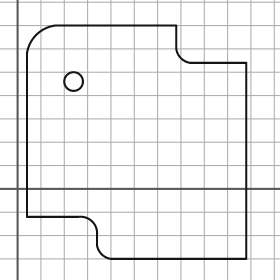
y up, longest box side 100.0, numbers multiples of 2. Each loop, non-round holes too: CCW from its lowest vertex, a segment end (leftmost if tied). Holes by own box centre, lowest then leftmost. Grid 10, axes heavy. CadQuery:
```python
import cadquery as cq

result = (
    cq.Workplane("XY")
    .moveTo(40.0, -30.0)
    .lineTo(98.0, -30.0)
    .lineTo(98.0, 54.0)
    .lineTo(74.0, 54.0)
    .threePointArc((70.0, 56.0), (68.0, 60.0))
    .lineTo(68.0, 70.0)
    .lineTo(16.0, 70.0)
    .threePointArc((8.0, 66.0), (4.0, 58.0))
    .lineTo(4.0, -12.0)
    .lineTo(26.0, -12.0)
    .threePointArc((32.0, -14.0), (34.0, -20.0))
    .lineTo(34.0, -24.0)
    .threePointArc((36.0, -28.0), (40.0, -30.0))
    .close()
    .moveTo(24.0, 46.0)
    .circle(4.0)
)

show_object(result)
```